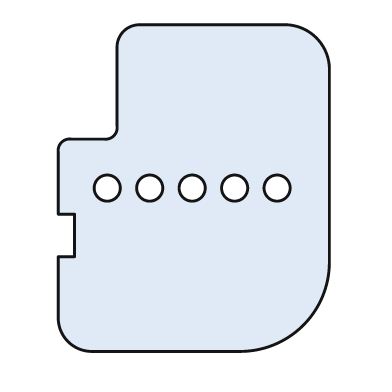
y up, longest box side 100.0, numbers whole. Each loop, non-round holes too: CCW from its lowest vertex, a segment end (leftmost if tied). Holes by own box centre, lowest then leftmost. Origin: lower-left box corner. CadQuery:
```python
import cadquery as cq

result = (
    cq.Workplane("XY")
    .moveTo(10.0, 0.0)
    .lineTo(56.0, 0.0)
    .threePointArc((75.0, 8.0), (83.0, 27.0))
    .lineTo(83.0, 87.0)
    .threePointArc((79.0, 96.0), (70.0, 100.0))
    .lineTo(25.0, 100.0)
    .threePointArc((20.0, 98.0), (18.0, 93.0))
    .lineTo(18.0, 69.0)
    .threePointArc((17.0, 66.0), (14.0, 65.0))
    .lineTo(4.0, 65.0)
    .threePointArc((1.0, 64.0), (0.0, 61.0))
    .lineTo(0.0, 42.0)
    .lineTo(5.0, 42.0)
    .lineTo(5.0, 29.0)
    .lineTo(0.0, 29.0)
    .lineTo(0.0, 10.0)
    .threePointArc((3.0, 3.0), (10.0, 0.0))
    .close()
    .moveTo(15.0, 50.0)
    .circle(4.0)
    .moveTo(28.0, 50.0)
    .circle(4.0)
    .moveTo(41.0, 50.0)
    .circle(4.0)
    .moveTo(54.0, 50.0)
    .circle(4.0)
    .moveTo(67.0, 50.0)
    .circle(4.0)
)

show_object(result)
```